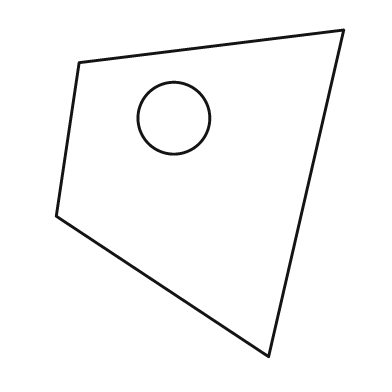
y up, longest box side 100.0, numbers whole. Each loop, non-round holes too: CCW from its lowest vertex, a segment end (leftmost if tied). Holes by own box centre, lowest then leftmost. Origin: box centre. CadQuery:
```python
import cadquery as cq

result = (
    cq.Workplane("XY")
    .moveTo(21.0, -50.0)
    .lineTo(44.0, 50.0)
    .lineTo(-37.0, 40.0)
    .lineTo(-44.0, -7.0)
    .close()
    .moveTo(-8.0, 23.0)
    .circle(11.0)
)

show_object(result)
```